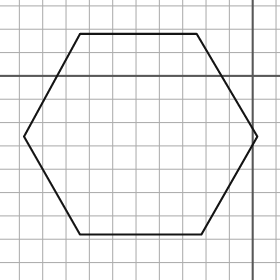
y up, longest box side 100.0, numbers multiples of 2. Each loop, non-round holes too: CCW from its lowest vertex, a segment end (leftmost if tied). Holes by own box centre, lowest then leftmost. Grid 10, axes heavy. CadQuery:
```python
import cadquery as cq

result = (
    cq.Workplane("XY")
    .moveTo(-74.0, -68.0)
    .lineTo(-22.0, -68.0)
    .lineTo(2.0, -26.0)
    .lineTo(-24.0, 18.0)
    .lineTo(-74.0, 18.0)
    .lineTo(-98.0, -26.0)
    .close()
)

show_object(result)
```